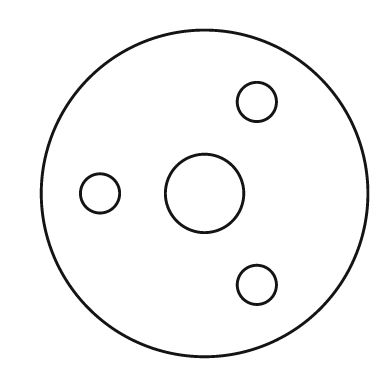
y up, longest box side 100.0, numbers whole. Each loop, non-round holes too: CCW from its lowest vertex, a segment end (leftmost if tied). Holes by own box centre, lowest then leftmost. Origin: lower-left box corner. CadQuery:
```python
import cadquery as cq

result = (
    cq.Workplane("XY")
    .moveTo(50.0, 50.0)
    .circle(50.0)
    .moveTo(66.0, 22.0)
    .circle(6.0)
    .moveTo(18.0, 50.0)
    .circle(6.0)
    .moveTo(50.0, 50.0)
    .circle(12.0)
    .moveTo(66.0, 78.0)
    .circle(6.0)
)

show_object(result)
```